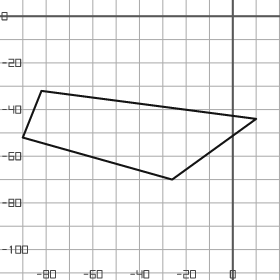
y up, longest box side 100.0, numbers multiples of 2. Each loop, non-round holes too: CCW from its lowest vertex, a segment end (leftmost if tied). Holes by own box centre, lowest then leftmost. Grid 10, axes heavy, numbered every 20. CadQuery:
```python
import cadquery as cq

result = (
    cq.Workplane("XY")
    .moveTo(-26.0, -70.0)
    .lineTo(10.0, -44.0)
    .lineTo(-82.0, -32.0)
    .lineTo(-90.0, -52.0)
    .close()
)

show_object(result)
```